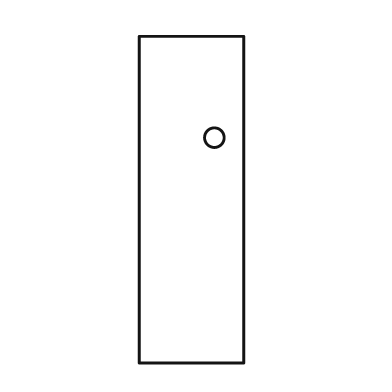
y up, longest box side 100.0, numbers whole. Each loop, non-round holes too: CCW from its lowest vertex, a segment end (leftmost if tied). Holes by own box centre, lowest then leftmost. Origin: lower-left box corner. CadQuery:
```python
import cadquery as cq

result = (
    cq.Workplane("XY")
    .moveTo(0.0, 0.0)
    .lineTo(32.0, 0.0)
    .lineTo(32.0, 100.0)
    .lineTo(0.0, 100.0)
    .close()
    .moveTo(23.0, 69.0)
    .circle(3.0)
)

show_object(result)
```